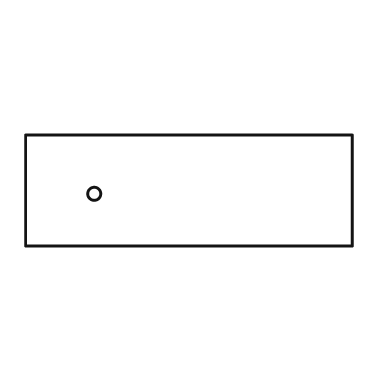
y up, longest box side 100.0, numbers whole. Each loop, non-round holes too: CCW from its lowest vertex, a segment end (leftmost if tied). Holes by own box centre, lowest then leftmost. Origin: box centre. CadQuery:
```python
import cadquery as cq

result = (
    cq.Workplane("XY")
    .moveTo(-50.0, -17.0)
    .lineTo(50.0, -17.0)
    .lineTo(50.0, 17.0)
    .lineTo(-50.0, 17.0)
    .close()
    .moveTo(-29.0, -1.0)
    .circle(2.0)
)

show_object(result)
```